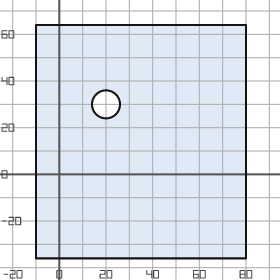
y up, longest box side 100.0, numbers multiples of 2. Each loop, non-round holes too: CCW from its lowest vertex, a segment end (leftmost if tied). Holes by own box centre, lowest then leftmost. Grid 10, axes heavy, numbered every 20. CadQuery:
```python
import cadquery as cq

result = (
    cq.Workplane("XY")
    .moveTo(-10.0, -36.0)
    .lineTo(80.0, -36.0)
    .lineTo(80.0, 64.0)
    .lineTo(-10.0, 64.0)
    .close()
    .moveTo(20.0, 30.0)
    .circle(6.0)
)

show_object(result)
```